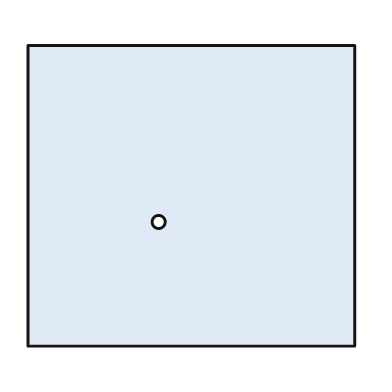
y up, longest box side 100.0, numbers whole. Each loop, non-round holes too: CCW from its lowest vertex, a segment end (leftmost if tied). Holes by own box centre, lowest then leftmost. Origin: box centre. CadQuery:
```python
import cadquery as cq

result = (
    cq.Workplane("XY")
    .moveTo(-50.0, -46.0)
    .lineTo(50.0, -46.0)
    .lineTo(50.0, 46.0)
    .lineTo(-50.0, 46.0)
    .close()
    .moveTo(-10.0, -8.0)
    .circle(2.0)
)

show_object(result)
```